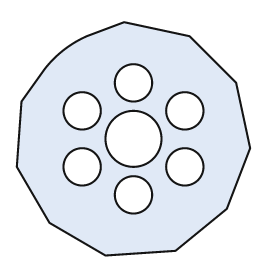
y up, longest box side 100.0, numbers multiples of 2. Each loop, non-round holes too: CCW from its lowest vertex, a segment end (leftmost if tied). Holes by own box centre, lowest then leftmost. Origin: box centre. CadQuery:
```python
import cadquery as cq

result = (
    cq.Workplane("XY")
    .moveTo(-12.0, -50.0)
    .lineTo(18.0, -48.0)
    .lineTo(40.0, -30.0)
    .lineTo(50.0, -4.0)
    .lineTo(44.0, 24.0)
    .lineTo(24.0, 44.0)
    .lineTo(-4.0, 50.0)
    .lineTo(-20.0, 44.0)
    .threePointArc((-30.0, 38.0), (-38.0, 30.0))
    .lineTo(-48.0, 16.0)
    .lineTo(-50.0, -12.0)
    .lineTo(-36.0, -36.0)
    .close()
    .moveTo(0.0, -24.0)
    .circle(8.0)
    .moveTo(-22.0, -12.0)
    .circle(8.0)
    .moveTo(22.0, -12.0)
    .circle(8.0)
    .moveTo(0.0, 0.0)
    .circle(12.0)
    .moveTo(-22.0, 12.0)
    .circle(8.0)
    .moveTo(22.0, 12.0)
    .circle(8.0)
    .moveTo(0.0, 24.0)
    .circle(8.0)
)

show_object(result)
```